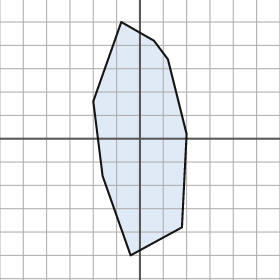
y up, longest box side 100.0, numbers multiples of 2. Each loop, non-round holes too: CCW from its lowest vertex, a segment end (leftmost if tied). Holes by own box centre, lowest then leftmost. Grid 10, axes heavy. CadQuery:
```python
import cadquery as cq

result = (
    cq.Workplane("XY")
    .moveTo(-4.0, -50.0)
    .lineTo(18.0, -38.0)
    .lineTo(20.0, 2.0)
    .lineTo(12.0, 34.0)
    .lineTo(6.0, 42.0)
    .lineTo(-8.0, 50.0)
    .lineTo(-20.0, 16.0)
    .lineTo(-16.0, -16.0)
    .close()
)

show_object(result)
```